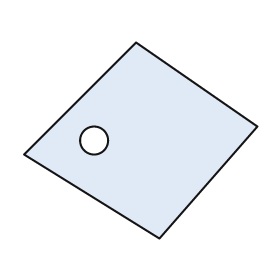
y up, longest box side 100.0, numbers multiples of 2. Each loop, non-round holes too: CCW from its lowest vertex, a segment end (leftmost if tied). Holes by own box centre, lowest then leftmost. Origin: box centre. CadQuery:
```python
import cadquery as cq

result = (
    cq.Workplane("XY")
    .moveTo(8.0, -42.0)
    .lineTo(50.0, 6.0)
    .lineTo(-2.0, 42.0)
    .lineTo(-50.0, -6.0)
    .close()
    .moveTo(-20.0, 0.0)
    .circle(6.0)
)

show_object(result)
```